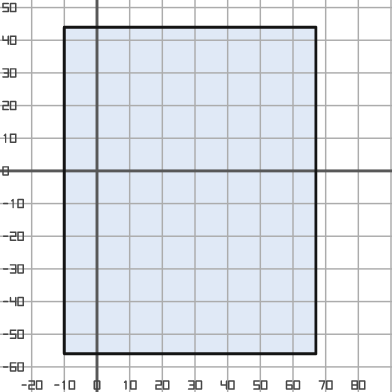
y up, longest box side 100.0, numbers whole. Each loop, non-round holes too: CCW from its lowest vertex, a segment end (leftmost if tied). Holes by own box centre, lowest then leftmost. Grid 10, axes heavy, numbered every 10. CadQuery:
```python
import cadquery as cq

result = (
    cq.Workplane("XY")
    .moveTo(-10.0, -56.0)
    .lineTo(67.0, -56.0)
    .lineTo(67.0, 44.0)
    .lineTo(-10.0, 44.0)
    .close()
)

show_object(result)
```